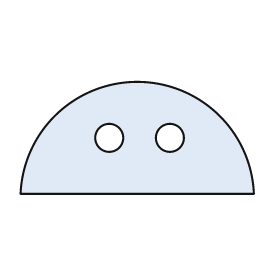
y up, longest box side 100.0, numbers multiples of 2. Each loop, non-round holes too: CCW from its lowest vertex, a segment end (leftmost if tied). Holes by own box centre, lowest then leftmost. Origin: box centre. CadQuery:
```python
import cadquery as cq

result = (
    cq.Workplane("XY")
    .moveTo(-50.0, -24.0)
    .lineTo(50.0, -24.0)
    .threePointArc((0.0, 24.0), (-50.0, -24.0))
    .close()
    .moveTo(-12.0, 0.0)
    .circle(6.0)
    .moveTo(14.0, 0.0)
    .circle(6.0)
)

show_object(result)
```